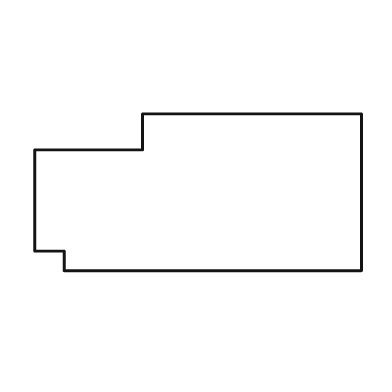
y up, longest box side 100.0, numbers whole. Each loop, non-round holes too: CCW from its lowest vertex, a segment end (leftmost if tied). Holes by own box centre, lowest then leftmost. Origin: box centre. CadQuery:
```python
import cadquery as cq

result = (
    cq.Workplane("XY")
    .moveTo(-41.0, -24.0)
    .lineTo(50.0, -24.0)
    .lineTo(50.0, 24.0)
    .lineTo(-17.0, 24.0)
    .lineTo(-17.0, 13.0)
    .lineTo(-50.0, 13.0)
    .lineTo(-50.0, -18.0)
    .lineTo(-41.0, -18.0)
    .close()
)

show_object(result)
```